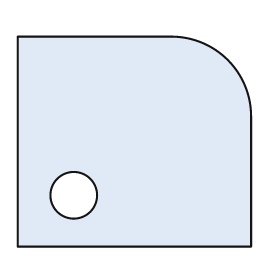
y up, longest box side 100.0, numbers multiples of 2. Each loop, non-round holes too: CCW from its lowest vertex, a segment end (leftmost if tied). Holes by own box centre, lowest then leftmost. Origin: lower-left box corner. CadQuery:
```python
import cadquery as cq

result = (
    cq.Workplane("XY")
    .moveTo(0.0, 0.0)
    .lineTo(100.0, 0.0)
    .lineTo(100.0, 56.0)
    .threePointArc((90.0, 80.0), (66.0, 90.0))
    .lineTo(0.0, 90.0)
    .close()
    .moveTo(24.0, 22.0)
    .circle(10.0)
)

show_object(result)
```